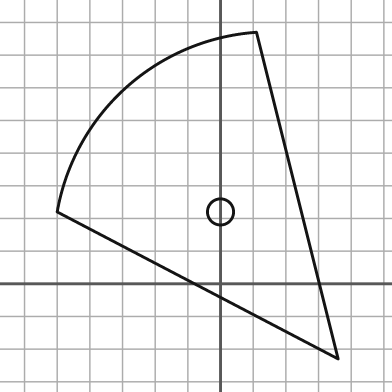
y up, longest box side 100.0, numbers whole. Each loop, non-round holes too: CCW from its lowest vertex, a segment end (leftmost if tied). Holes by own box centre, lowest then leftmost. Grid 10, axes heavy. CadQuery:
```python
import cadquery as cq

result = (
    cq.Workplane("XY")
    .moveTo(36.0, -23.0)
    .lineTo(11.0, 77.0)
    .threePointArc((-29.0, 60.0), (-50.0, 22.0))
    .close()
    .moveTo(0.0, 22.0)
    .circle(4.0)
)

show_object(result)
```